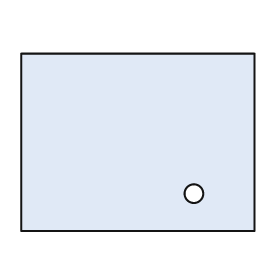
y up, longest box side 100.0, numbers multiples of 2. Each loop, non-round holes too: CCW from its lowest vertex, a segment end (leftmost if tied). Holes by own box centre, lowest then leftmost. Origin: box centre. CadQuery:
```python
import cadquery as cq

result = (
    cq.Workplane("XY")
    .moveTo(-50.0, -38.0)
    .lineTo(50.0, -38.0)
    .lineTo(50.0, 38.0)
    .lineTo(-50.0, 38.0)
    .close()
    .moveTo(24.0, -22.0)
    .circle(4.0)
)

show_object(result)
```